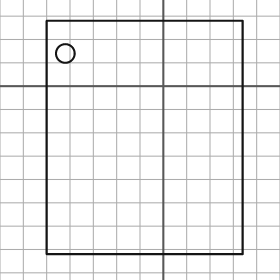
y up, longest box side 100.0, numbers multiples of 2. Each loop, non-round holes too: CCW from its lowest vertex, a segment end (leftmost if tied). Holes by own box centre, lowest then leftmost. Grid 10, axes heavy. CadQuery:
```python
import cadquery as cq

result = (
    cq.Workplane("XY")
    .moveTo(-50.0, -72.0)
    .lineTo(34.0, -72.0)
    .lineTo(34.0, 28.0)
    .lineTo(-50.0, 28.0)
    .close()
    .moveTo(-42.0, 14.0)
    .circle(4.0)
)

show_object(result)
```